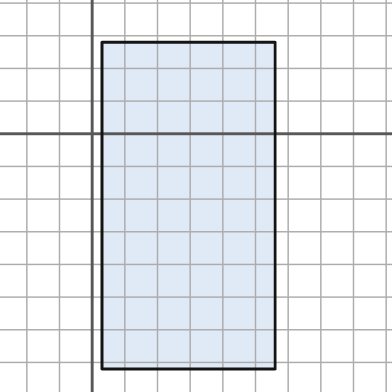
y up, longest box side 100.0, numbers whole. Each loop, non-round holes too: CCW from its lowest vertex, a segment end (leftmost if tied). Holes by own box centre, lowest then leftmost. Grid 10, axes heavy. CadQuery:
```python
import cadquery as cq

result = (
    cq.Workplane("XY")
    .moveTo(3.0, -72.0)
    .lineTo(56.0, -72.0)
    .lineTo(56.0, 28.0)
    .lineTo(3.0, 28.0)
    .close()
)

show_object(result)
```